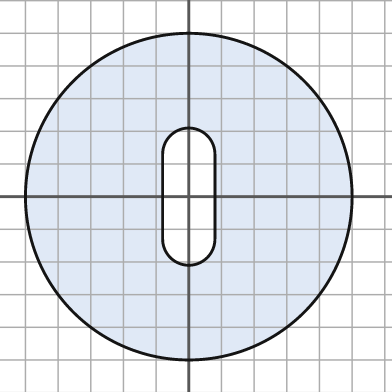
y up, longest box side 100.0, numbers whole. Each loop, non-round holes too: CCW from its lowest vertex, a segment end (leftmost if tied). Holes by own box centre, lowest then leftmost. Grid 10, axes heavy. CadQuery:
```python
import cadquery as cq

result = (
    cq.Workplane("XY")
    .moveTo(0.0, 0.0)
    .circle(50.0)
    .moveTo(-8.0, -13.0)
    .threePointArc((0.0, -21.0), (8.0, -13.0))
    .lineTo(8.0, 13.0)
    .threePointArc((0.0, 21.0), (-8.0, 13.0))
    .close()
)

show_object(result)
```